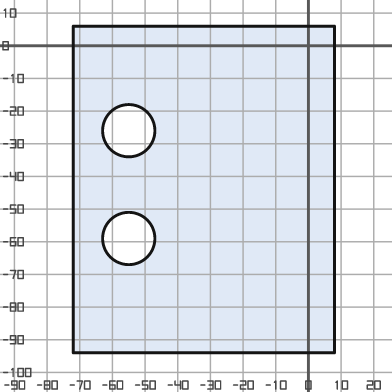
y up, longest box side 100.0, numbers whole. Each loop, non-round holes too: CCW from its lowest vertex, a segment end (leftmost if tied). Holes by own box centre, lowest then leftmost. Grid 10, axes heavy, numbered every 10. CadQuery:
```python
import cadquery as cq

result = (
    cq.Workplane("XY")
    .moveTo(-72.0, -94.0)
    .lineTo(8.0, -94.0)
    .lineTo(8.0, 6.0)
    .lineTo(-72.0, 6.0)
    .close()
    .moveTo(-55.0, -59.0)
    .circle(8.0)
    .moveTo(-55.0, -26.0)
    .circle(8.0)
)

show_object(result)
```